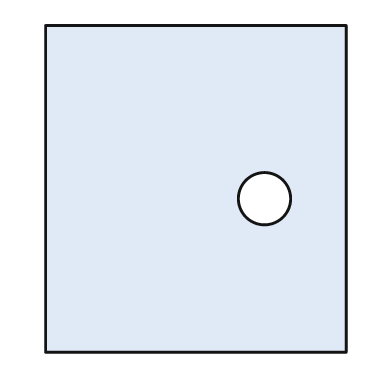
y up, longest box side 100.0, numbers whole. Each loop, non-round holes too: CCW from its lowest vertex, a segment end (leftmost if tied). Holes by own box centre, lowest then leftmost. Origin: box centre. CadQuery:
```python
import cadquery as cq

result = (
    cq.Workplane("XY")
    .moveTo(-46.0, -50.0)
    .lineTo(46.0, -50.0)
    .lineTo(46.0, 50.0)
    .lineTo(-46.0, 50.0)
    .close()
    .moveTo(21.0, -3.0)
    .circle(8.0)
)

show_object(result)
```